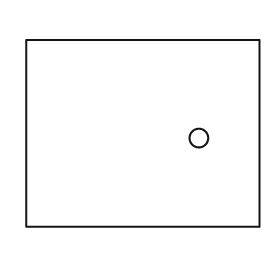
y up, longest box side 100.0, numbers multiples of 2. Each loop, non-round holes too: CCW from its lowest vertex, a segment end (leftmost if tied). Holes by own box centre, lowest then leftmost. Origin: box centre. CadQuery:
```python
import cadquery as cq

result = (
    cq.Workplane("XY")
    .moveTo(-50.0, -40.0)
    .lineTo(50.0, -40.0)
    .lineTo(50.0, 40.0)
    .lineTo(-50.0, 40.0)
    .close()
    .moveTo(24.0, -2.0)
    .circle(4.0)
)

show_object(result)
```